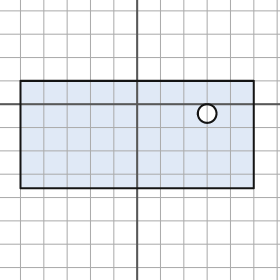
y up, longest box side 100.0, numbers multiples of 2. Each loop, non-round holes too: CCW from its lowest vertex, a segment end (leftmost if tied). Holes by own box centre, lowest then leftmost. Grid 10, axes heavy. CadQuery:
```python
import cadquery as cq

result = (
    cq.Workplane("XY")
    .moveTo(-50.0, -36.0)
    .lineTo(50.0, -36.0)
    .lineTo(50.0, 10.0)
    .lineTo(-50.0, 10.0)
    .close()
    .moveTo(30.0, -4.0)
    .circle(4.0)
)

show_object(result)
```